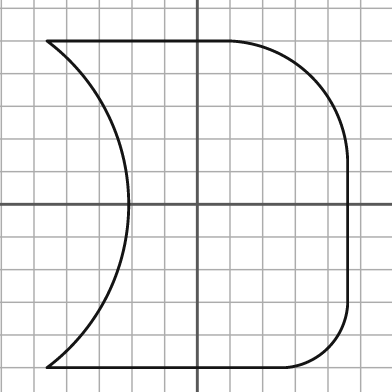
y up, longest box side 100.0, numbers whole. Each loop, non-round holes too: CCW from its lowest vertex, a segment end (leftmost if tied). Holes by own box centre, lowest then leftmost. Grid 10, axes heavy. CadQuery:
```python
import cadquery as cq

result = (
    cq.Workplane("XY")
    .moveTo(-46.0, -50.0)
    .lineTo(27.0, -50.0)
    .threePointArc((40.0, -44.0), (46.0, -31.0))
    .lineTo(46.0, 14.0)
    .threePointArc((35.0, 39.0), (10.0, 50.0))
    .lineTo(-46.0, 50.0)
    .threePointArc((-21.0, 0.0), (-46.0, -50.0))
    .close()
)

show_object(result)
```